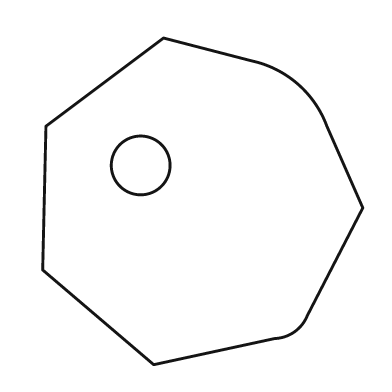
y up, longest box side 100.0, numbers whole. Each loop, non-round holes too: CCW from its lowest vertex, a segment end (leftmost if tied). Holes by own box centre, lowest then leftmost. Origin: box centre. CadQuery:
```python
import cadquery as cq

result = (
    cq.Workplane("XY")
    .moveTo(-15.0, -50.0)
    .lineTo(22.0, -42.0)
    .threePointArc((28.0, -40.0), (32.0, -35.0))
    .lineTo(49.0, -2.0)
    .lineTo(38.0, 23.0)
    .threePointArc((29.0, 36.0), (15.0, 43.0))
    .lineTo(-12.0, 50.0)
    .lineTo(-48.0, 23.0)
    .lineTo(-49.0, -21.0)
    .close()
    .moveTo(-19.0, 11.0)
    .circle(9.0)
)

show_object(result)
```